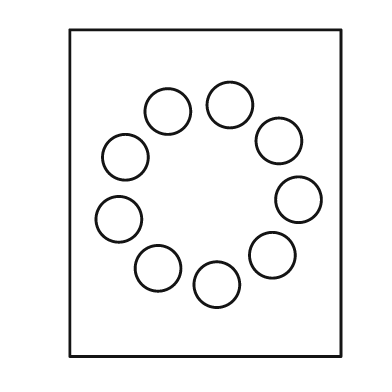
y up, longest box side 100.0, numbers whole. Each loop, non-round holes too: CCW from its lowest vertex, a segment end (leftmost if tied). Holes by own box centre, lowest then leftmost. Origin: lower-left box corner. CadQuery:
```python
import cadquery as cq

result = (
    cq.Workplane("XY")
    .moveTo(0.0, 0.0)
    .lineTo(83.0, 0.0)
    .lineTo(83.0, 100.0)
    .lineTo(0.0, 100.0)
    .close()
    .moveTo(45.0, 22.0)
    .circle(7.0)
    .moveTo(27.0, 27.0)
    .circle(7.0)
    .moveTo(62.0, 31.0)
    .circle(7.0)
    .moveTo(15.0, 42.0)
    .circle(7.0)
    .moveTo(70.0, 48.0)
    .circle(7.0)
    .moveTo(17.0, 61.0)
    .circle(7.0)
    .moveTo(64.0, 66.0)
    .circle(7.0)
    .moveTo(30.0, 75.0)
    .circle(7.0)
    .moveTo(49.0, 77.0)
    .circle(7.0)
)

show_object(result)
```